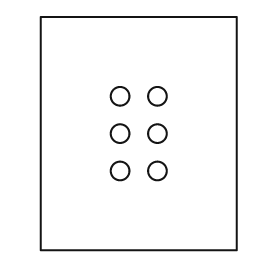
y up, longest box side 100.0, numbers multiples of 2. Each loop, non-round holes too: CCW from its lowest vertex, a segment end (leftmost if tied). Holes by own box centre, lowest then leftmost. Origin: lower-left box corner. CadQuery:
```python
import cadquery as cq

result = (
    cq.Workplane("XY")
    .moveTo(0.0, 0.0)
    .lineTo(84.0, 0.0)
    .lineTo(84.0, 100.0)
    .lineTo(0.0, 100.0)
    .close()
    .moveTo(34.0, 34.0)
    .circle(4.0)
    .moveTo(50.0, 34.0)
    .circle(4.0)
    .moveTo(34.0, 50.0)
    .circle(4.0)
    .moveTo(50.0, 50.0)
    .circle(4.0)
    .moveTo(34.0, 66.0)
    .circle(4.0)
    .moveTo(50.0, 66.0)
    .circle(4.0)
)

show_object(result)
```